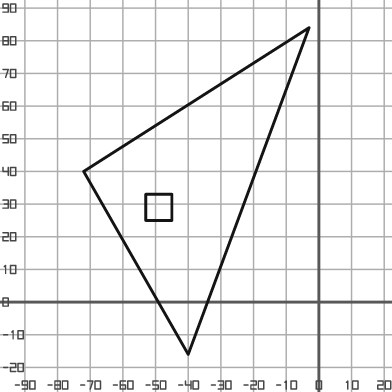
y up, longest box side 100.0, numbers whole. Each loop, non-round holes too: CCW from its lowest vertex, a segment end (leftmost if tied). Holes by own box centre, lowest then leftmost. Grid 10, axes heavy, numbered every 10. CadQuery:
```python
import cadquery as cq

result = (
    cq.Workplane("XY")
    .moveTo(-40.0, -16.0)
    .lineTo(-3.0, 84.0)
    .lineTo(-72.0, 40.0)
    .close()
    .moveTo(-53.0, 25.0)
    .lineTo(-45.0, 25.0)
    .lineTo(-45.0, 33.0)
    .lineTo(-53.0, 33.0)
    .close()
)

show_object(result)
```